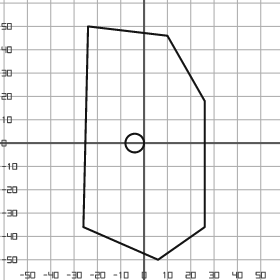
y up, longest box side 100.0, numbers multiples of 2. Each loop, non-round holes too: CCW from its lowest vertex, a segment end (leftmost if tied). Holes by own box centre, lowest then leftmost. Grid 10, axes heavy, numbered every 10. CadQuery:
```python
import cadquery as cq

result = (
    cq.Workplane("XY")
    .moveTo(6.0, -50.0)
    .lineTo(26.0, -36.0)
    .lineTo(26.0, 18.0)
    .lineTo(10.0, 46.0)
    .lineTo(-24.0, 50.0)
    .lineTo(-26.0, -36.0)
    .close()
    .moveTo(-4.0, 0.0)
    .circle(4.0)
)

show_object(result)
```